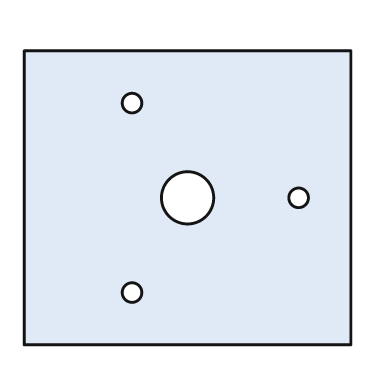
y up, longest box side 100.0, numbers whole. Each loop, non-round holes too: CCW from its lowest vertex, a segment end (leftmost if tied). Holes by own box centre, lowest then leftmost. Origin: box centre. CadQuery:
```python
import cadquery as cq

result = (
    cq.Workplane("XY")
    .moveTo(-50.0, -45.0)
    .lineTo(50.0, -45.0)
    .lineTo(50.0, 45.0)
    .lineTo(-50.0, 45.0)
    .close()
    .moveTo(-17.0, -29.0)
    .circle(3.0)
    .moveTo(0.0, 0.0)
    .circle(8.0)
    .moveTo(34.0, 0.0)
    .circle(3.0)
    .moveTo(-17.0, 29.0)
    .circle(3.0)
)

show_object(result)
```